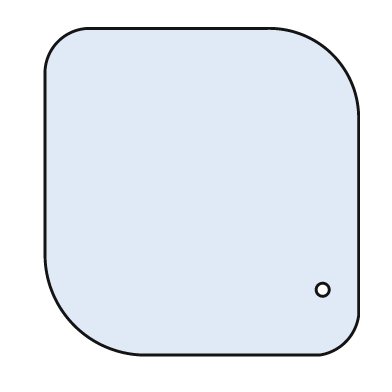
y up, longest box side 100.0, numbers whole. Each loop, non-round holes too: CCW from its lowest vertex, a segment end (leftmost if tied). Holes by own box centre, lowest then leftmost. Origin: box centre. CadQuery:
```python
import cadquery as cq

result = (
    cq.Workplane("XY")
    .moveTo(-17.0, -50.0)
    .lineTo(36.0, -50.0)
    .threePointArc((44.0, -46.0), (48.0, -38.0))
    .lineTo(48.0, 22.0)
    .threePointArc((40.0, 42.0), (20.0, 50.0))
    .lineTo(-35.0, 50.0)
    .threePointArc((-44.0, 46.0), (-48.0, 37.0))
    .lineTo(-48.0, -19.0)
    .threePointArc((-39.0, -41.0), (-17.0, -50.0))
    .close()
    .moveTo(37.0, -30.0)
    .circle(2.0)
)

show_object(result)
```